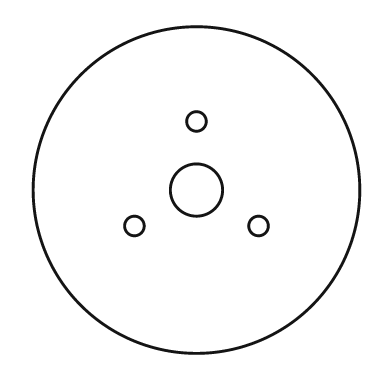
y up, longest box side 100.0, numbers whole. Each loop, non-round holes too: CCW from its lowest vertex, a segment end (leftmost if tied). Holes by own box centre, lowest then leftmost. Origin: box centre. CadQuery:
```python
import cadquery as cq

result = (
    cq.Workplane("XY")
    .moveTo(0.0, 0.0)
    .circle(50.0)
    .moveTo(-19.0, -11.0)
    .circle(3.0)
    .moveTo(19.0, -11.0)
    .circle(3.0)
    .moveTo(0.0, 0.0)
    .circle(8.0)
    .moveTo(0.0, 21.0)
    .circle(3.0)
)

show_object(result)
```